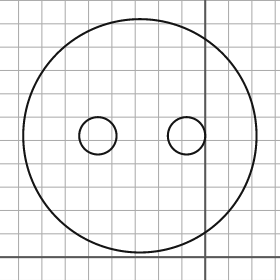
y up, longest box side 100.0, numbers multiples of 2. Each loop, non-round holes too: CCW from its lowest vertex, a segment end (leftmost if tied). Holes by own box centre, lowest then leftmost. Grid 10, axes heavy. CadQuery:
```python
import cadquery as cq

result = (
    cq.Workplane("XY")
    .moveTo(-28.0, 52.0)
    .circle(50.0)
    .moveTo(-46.0, 52.0)
    .circle(8.0)
    .moveTo(-8.0, 52.0)
    .circle(8.0)
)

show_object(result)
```